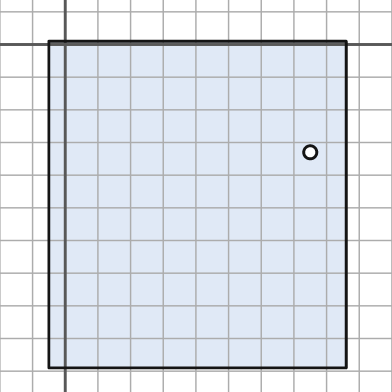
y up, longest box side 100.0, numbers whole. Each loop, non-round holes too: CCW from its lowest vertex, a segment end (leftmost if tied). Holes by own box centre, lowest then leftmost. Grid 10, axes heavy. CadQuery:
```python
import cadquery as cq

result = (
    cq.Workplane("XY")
    .moveTo(-5.0, -99.0)
    .lineTo(86.0, -99.0)
    .lineTo(86.0, 1.0)
    .lineTo(-5.0, 1.0)
    .close()
    .moveTo(75.0, -33.0)
    .circle(2.0)
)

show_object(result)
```